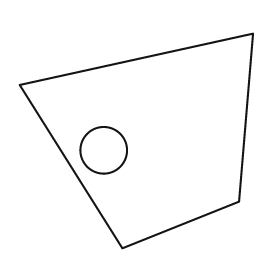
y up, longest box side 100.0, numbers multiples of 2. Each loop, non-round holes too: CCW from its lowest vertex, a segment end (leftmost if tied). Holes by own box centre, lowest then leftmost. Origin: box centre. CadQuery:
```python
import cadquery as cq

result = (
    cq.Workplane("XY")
    .moveTo(-6.0, -46.0)
    .lineTo(44.0, -26.0)
    .lineTo(50.0, 46.0)
    .lineTo(-50.0, 24.0)
    .close()
    .moveTo(-14.0, -4.0)
    .circle(10.0)
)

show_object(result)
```